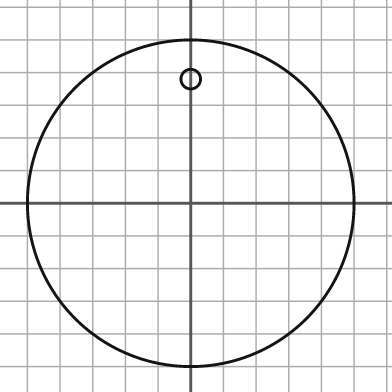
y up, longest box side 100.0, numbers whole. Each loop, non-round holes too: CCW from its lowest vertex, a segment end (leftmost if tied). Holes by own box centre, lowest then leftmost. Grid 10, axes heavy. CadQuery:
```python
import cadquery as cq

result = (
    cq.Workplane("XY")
    .moveTo(0.0, 0.0)
    .circle(50.0)
    .moveTo(0.0, 38.0)
    .circle(3.0)
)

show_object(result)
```